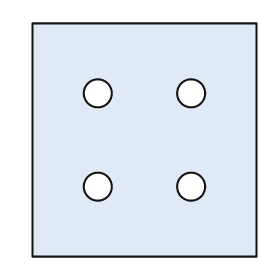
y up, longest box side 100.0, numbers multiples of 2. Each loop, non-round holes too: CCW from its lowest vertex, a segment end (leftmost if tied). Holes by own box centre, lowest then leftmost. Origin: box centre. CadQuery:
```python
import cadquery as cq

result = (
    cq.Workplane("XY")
    .moveTo(-48.0, -50.0)
    .lineTo(48.0, -50.0)
    .lineTo(48.0, 50.0)
    .lineTo(-48.0, 50.0)
    .close()
    .moveTo(-20.0, -20.0)
    .circle(6.0)
    .moveTo(20.0, -20.0)
    .circle(6.0)
    .moveTo(-20.0, 20.0)
    .circle(6.0)
    .moveTo(20.0, 20.0)
    .circle(6.0)
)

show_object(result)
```